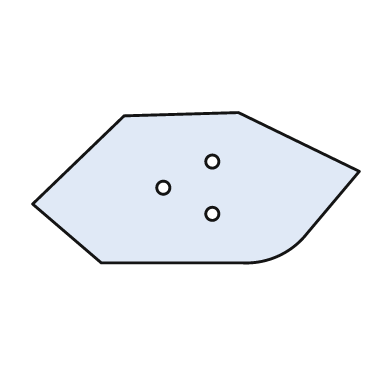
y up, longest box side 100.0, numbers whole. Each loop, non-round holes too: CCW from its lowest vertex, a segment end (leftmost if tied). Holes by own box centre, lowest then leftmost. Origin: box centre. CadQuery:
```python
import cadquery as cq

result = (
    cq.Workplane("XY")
    .moveTo(-29.0, -23.0)
    .lineTo(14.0, -23.0)
    .threePointArc((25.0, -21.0), (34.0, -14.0))
    .lineTo(50.0, 5.0)
    .lineTo(13.0, 23.0)
    .lineTo(-22.0, 22.0)
    .lineTo(-50.0, -5.0)
    .close()
    .moveTo(5.0, -8.0)
    .circle(2.0)
    .moveTo(-10.0, 0.0)
    .circle(2.0)
    .moveTo(5.0, 8.0)
    .circle(2.0)
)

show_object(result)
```